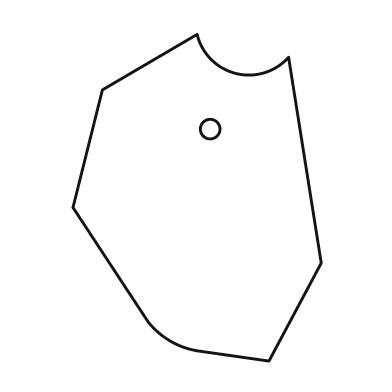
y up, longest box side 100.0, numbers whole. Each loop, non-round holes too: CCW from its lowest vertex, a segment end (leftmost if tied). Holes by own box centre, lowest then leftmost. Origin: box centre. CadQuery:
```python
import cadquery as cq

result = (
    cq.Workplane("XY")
    .moveTo(22.0, -50.0)
    .lineTo(38.0, -20.0)
    .lineTo(28.0, 43.0)
    .threePointArc((12.0, 38.0), (0.0, 50.0))
    .lineTo(-29.0, 33.0)
    .lineTo(-38.0, -3.0)
    .lineTo(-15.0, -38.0)
    .threePointArc((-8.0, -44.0), (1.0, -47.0))
    .close()
    .moveTo(4.0, 21.0)
    .circle(3.0)
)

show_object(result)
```